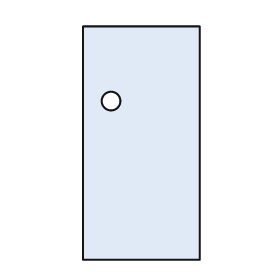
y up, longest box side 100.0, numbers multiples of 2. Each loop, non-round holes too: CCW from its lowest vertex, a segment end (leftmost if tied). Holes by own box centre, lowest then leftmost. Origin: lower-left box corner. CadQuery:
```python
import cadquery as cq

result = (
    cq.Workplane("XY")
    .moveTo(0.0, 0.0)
    .lineTo(50.0, 0.0)
    .lineTo(50.0, 100.0)
    .lineTo(0.0, 100.0)
    .close()
    .moveTo(12.0, 68.0)
    .circle(4.0)
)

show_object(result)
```